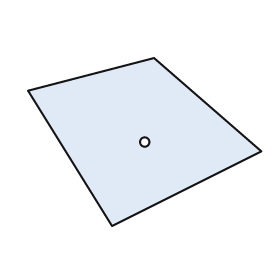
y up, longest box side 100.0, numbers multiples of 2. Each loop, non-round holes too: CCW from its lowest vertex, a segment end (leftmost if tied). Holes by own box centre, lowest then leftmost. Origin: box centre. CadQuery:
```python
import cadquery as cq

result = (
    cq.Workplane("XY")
    .moveTo(-14.0, -36.0)
    .lineTo(50.0, -4.0)
    .lineTo(4.0, 36.0)
    .lineTo(-50.0, 22.0)
    .close()
    .moveTo(0.0, 0.0)
    .circle(2.0)
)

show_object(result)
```